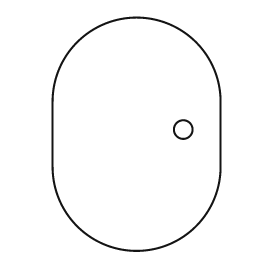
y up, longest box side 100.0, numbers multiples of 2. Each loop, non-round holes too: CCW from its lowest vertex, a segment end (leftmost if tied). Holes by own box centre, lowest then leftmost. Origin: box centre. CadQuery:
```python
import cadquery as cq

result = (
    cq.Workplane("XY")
    .moveTo(-36.0, -14.0)
    .threePointArc((0.0, -50.0), (36.0, -14.0))
    .lineTo(36.0, 14.0)
    .threePointArc((0.0, 50.0), (-36.0, 14.0))
    .close()
    .moveTo(20.0, 2.0)
    .circle(4.0)
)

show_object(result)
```